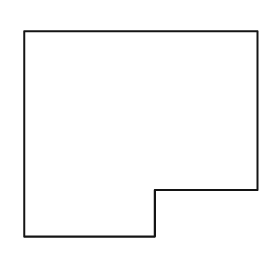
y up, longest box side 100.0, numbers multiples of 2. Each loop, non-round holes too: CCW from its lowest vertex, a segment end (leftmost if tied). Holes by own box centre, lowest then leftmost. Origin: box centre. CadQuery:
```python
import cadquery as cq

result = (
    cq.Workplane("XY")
    .moveTo(-50.0, -44.0)
    .lineTo(6.0, -44.0)
    .lineTo(6.0, -24.0)
    .lineTo(50.0, -24.0)
    .lineTo(50.0, 44.0)
    .lineTo(-50.0, 44.0)
    .close()
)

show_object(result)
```